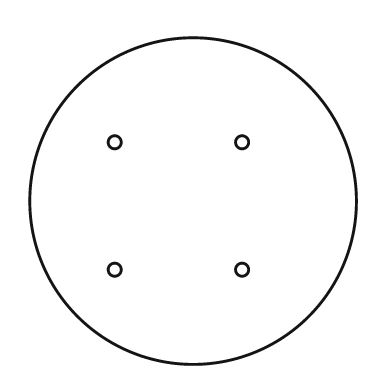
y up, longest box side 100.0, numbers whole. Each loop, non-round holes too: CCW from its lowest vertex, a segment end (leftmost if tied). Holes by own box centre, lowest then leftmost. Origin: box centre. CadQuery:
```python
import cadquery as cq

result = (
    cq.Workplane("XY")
    .moveTo(0.0, 0.0)
    .circle(50.0)
    .moveTo(-24.0, -21.0)
    .circle(2.0)
    .moveTo(15.0, -21.0)
    .circle(2.0)
    .moveTo(-24.0, 18.0)
    .circle(2.0)
    .moveTo(15.0, 18.0)
    .circle(2.0)
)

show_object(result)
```